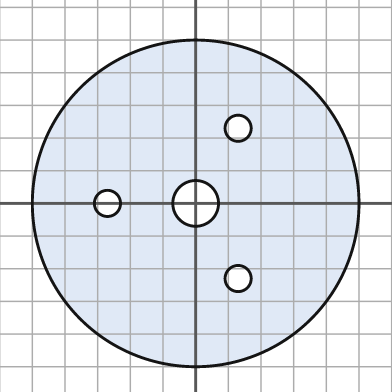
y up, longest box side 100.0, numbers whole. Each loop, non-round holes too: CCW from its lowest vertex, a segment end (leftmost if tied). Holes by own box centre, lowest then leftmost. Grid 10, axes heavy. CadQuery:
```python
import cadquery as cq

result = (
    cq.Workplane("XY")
    .moveTo(0.0, 0.0)
    .circle(50.0)
    .moveTo(13.0, -23.0)
    .circle(4.0)
    .moveTo(-27.0, 0.0)
    .circle(4.0)
    .moveTo(0.0, 0.0)
    .circle(7.0)
    .moveTo(13.0, 23.0)
    .circle(4.0)
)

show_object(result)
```